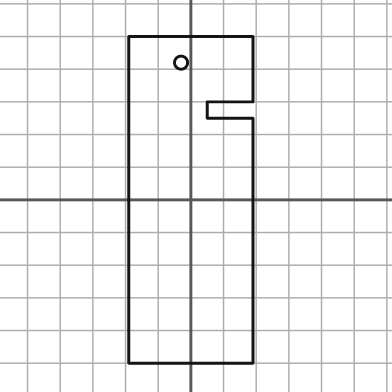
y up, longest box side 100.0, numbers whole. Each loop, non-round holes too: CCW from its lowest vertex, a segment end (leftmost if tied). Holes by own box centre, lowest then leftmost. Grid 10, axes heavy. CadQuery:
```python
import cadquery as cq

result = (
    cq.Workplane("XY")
    .moveTo(-19.0, -50.0)
    .lineTo(19.0, -50.0)
    .lineTo(19.0, 25.0)
    .lineTo(5.0, 25.0)
    .lineTo(5.0, 30.0)
    .lineTo(19.0, 30.0)
    .lineTo(19.0, 50.0)
    .lineTo(-19.0, 50.0)
    .close()
    .moveTo(-3.0, 42.0)
    .circle(2.0)
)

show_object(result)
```